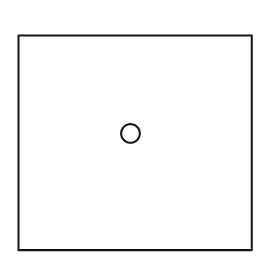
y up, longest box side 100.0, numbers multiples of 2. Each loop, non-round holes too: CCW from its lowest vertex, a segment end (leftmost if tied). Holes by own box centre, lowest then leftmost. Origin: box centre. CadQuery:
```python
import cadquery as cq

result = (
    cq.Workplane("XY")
    .moveTo(-50.0, -46.0)
    .lineTo(50.0, -46.0)
    .lineTo(50.0, 46.0)
    .lineTo(-50.0, 46.0)
    .close()
    .moveTo(-2.0, 4.0)
    .circle(4.0)
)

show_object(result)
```